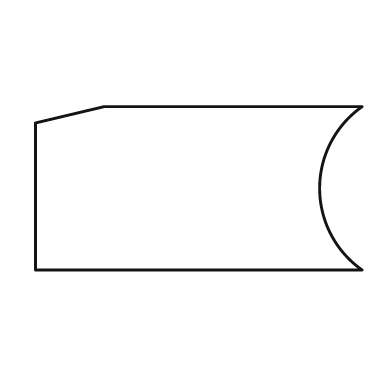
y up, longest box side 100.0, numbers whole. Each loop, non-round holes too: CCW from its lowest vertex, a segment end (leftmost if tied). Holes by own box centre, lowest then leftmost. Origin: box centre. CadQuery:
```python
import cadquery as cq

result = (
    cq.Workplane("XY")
    .moveTo(-50.0, -25.0)
    .lineTo(50.0, -25.0)
    .threePointArc((37.0, 0.0), (50.0, 25.0))
    .lineTo(-29.0, 25.0)
    .lineTo(-50.0, 20.0)
    .close()
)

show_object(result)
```